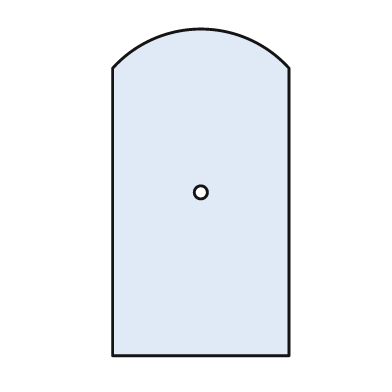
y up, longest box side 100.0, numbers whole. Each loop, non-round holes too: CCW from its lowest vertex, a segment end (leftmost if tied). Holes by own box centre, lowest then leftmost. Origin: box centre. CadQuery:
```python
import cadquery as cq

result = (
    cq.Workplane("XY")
    .moveTo(-27.0, -50.0)
    .lineTo(27.0, -50.0)
    .lineTo(27.0, 38.0)
    .threePointArc((0.0, 50.0), (-27.0, 38.0))
    .close()
    .moveTo(0.0, 0.0)
    .circle(2.0)
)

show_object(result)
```